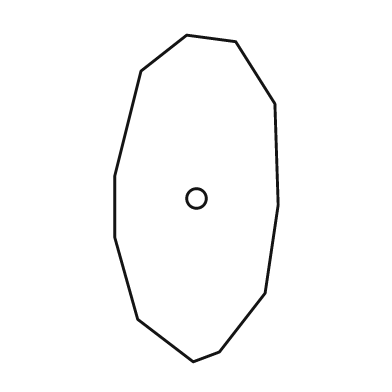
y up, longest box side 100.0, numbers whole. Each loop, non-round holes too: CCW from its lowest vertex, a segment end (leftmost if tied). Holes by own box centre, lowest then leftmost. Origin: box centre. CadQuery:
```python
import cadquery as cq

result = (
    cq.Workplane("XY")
    .moveTo(-1.0, -50.0)
    .lineTo(7.0, -47.0)
    .lineTo(21.0, -29.0)
    .lineTo(25.0, -2.0)
    .lineTo(24.0, 29.0)
    .lineTo(12.0, 48.0)
    .lineTo(-3.0, 50.0)
    .lineTo(-17.0, 39.0)
    .lineTo(-25.0, 7.0)
    .lineTo(-25.0, -12.0)
    .lineTo(-18.0, -37.0)
    .close()
    .moveTo(0.0, 0.0)
    .circle(3.0)
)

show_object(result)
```